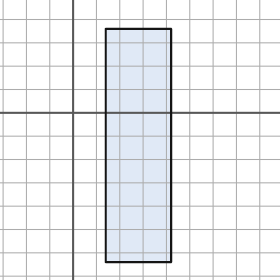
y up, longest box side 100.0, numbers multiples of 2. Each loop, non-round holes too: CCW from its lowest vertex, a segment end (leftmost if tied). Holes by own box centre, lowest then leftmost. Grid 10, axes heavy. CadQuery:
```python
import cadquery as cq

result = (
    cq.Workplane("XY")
    .moveTo(14.0, -64.0)
    .lineTo(42.0, -64.0)
    .lineTo(42.0, 36.0)
    .lineTo(14.0, 36.0)
    .close()
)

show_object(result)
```